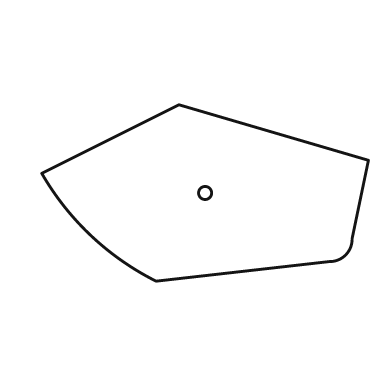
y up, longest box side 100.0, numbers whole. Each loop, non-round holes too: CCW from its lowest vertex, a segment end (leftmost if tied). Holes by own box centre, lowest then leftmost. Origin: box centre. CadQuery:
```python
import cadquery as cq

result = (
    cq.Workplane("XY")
    .moveTo(-15.0, -27.0)
    .lineTo(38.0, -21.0)
    .threePointArc((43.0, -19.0), (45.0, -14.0))
    .lineTo(50.0, 10.0)
    .lineTo(-8.0, 27.0)
    .lineTo(-50.0, 6.0)
    .threePointArc((-35.0, -13.0), (-15.0, -27.0))
    .close()
    .moveTo(0.0, 0.0)
    .circle(2.0)
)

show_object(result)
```